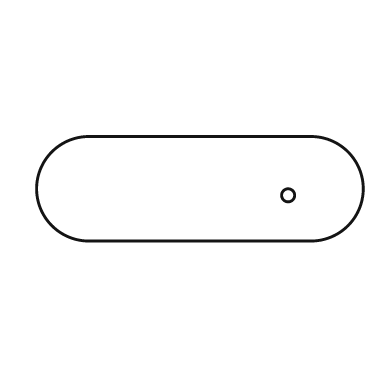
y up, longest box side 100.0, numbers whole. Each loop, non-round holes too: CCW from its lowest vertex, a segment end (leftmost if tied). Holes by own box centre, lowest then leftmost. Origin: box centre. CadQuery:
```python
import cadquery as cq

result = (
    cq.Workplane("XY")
    .moveTo(-34.0, -16.0)
    .lineTo(34.0, -16.0)
    .threePointArc((50.0, 0.0), (34.0, 16.0))
    .lineTo(-34.0, 16.0)
    .threePointArc((-50.0, 0.0), (-34.0, -16.0))
    .close()
    .moveTo(27.0, -2.0)
    .circle(2.0)
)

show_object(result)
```